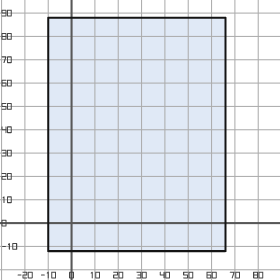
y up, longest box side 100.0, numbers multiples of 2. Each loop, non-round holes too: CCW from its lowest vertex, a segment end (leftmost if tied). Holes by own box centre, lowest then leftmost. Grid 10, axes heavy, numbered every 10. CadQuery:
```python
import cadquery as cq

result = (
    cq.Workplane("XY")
    .moveTo(-10.0, -12.0)
    .lineTo(66.0, -12.0)
    .lineTo(66.0, 88.0)
    .lineTo(-10.0, 88.0)
    .close()
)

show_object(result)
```